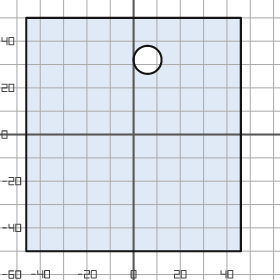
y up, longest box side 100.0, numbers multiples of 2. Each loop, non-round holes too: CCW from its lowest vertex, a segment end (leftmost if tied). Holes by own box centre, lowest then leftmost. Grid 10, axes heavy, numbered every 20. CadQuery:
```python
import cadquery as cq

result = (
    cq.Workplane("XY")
    .moveTo(-46.0, -50.0)
    .lineTo(46.0, -50.0)
    .lineTo(46.0, 50.0)
    .lineTo(-46.0, 50.0)
    .close()
    .moveTo(6.0, 32.0)
    .circle(6.0)
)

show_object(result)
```